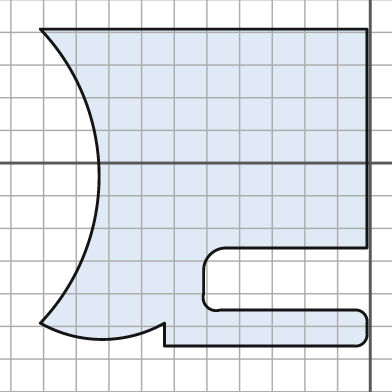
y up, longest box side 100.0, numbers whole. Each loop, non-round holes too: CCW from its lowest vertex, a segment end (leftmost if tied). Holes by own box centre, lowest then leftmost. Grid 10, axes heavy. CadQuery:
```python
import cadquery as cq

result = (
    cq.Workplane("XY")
    .moveTo(-63.0, -56.0)
    .lineTo(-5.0, -56.0)
    .threePointArc((-2.0, -55.0), (-1.0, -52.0))
    .lineTo(-1.0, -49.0)
    .threePointArc((-2.0, -46.0), (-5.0, -45.0))
    .lineTo(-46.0, -45.0)
    .threePointArc((-50.0, -44.0), (-51.0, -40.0))
    .lineTo(-51.0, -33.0)
    .threePointArc((-49.0, -28.0), (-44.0, -26.0))
    .lineTo(-1.0, -26.0)
    .lineTo(-1.0, 41.0)
    .lineTo(-101.0, 41.0)
    .threePointArc((-83.0, -4.0), (-101.0, -49.0))
    .threePointArc((-82.0, -54.0), (-63.0, -49.0))
    .close()
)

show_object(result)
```